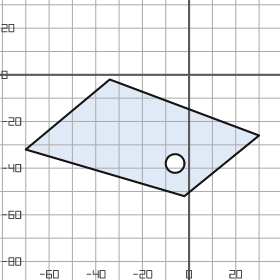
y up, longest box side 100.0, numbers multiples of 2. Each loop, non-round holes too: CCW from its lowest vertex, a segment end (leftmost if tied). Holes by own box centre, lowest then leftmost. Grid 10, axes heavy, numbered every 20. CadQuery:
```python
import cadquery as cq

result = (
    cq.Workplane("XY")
    .moveTo(-2.0, -52.0)
    .lineTo(30.0, -26.0)
    .lineTo(-34.0, -2.0)
    .lineTo(-70.0, -32.0)
    .close()
    .moveTo(-6.0, -38.0)
    .circle(4.0)
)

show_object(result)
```